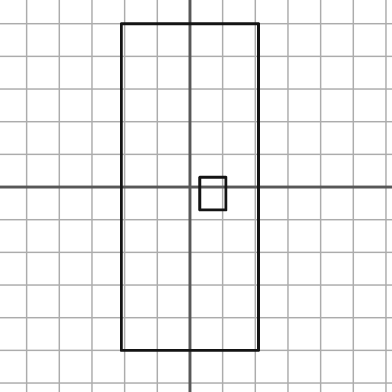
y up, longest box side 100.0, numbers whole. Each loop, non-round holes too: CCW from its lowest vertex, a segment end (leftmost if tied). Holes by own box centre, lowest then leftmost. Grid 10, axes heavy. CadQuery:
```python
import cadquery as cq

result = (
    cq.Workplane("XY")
    .moveTo(-21.0, -50.0)
    .lineTo(21.0, -50.0)
    .lineTo(21.0, 50.0)
    .lineTo(-21.0, 50.0)
    .close()
    .moveTo(3.0, -7.0)
    .lineTo(11.0, -7.0)
    .lineTo(11.0, 3.0)
    .lineTo(3.0, 3.0)
    .close()
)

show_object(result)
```